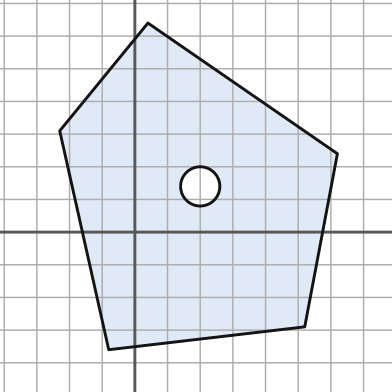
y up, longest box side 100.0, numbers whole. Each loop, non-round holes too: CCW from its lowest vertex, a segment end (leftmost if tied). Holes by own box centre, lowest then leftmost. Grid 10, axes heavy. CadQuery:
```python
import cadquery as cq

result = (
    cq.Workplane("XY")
    .moveTo(-8.0, -36.0)
    .lineTo(52.0, -29.0)
    .lineTo(62.0, 24.0)
    .lineTo(4.0, 64.0)
    .lineTo(-23.0, 31.0)
    .close()
    .moveTo(20.0, 14.0)
    .circle(6.0)
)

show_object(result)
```